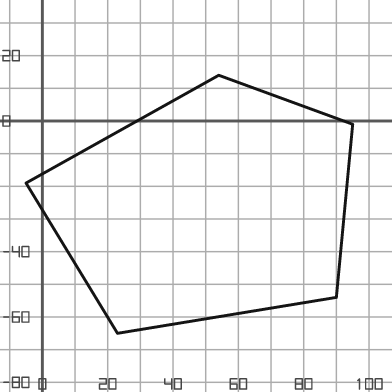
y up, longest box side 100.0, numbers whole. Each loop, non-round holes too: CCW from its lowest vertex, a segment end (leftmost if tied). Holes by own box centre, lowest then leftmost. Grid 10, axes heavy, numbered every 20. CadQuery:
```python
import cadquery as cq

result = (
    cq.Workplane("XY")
    .moveTo(23.0, -65.0)
    .lineTo(90.0, -54.0)
    .lineTo(95.0, -1.0)
    .lineTo(54.0, 14.0)
    .lineTo(-5.0, -19.0)
    .close()
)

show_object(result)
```